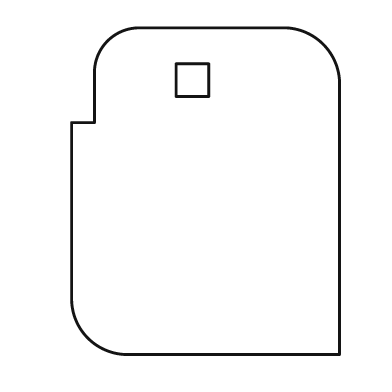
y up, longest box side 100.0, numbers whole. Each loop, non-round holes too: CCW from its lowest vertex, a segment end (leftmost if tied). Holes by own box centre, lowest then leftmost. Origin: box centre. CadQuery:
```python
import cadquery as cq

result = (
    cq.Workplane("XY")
    .moveTo(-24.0, -50.0)
    .lineTo(41.0, -50.0)
    .lineTo(41.0, 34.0)
    .threePointArc((36.0, 45.0), (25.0, 50.0))
    .lineTo(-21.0, 50.0)
    .threePointArc((-30.0, 46.0), (-34.0, 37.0))
    .lineTo(-34.0, 21.0)
    .lineTo(-41.0, 21.0)
    .lineTo(-41.0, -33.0)
    .threePointArc((-36.0, -45.0), (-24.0, -50.0))
    .close()
    .moveTo(-9.0, 29.0)
    .lineTo(1.0, 29.0)
    .lineTo(1.0, 39.0)
    .lineTo(-9.0, 39.0)
    .close()
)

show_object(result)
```